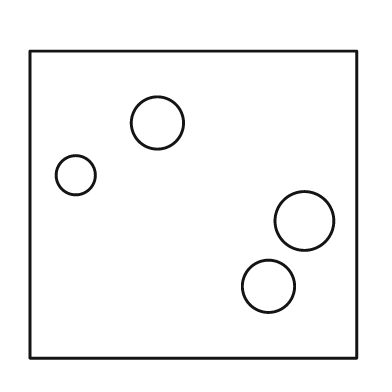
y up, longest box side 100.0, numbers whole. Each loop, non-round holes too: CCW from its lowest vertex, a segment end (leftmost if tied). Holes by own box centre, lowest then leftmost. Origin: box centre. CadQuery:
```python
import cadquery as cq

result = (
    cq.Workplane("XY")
    .moveTo(-50.0, -47.0)
    .lineTo(50.0, -47.0)
    .lineTo(50.0, 47.0)
    .lineTo(-50.0, 47.0)
    .close()
    .moveTo(23.0, -25.0)
    .circle(8.0)
    .moveTo(34.0, -5.0)
    .circle(9.0)
    .moveTo(-36.0, 9.0)
    .circle(6.0)
    .moveTo(-11.0, 25.0)
    .circle(8.0)
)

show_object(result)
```